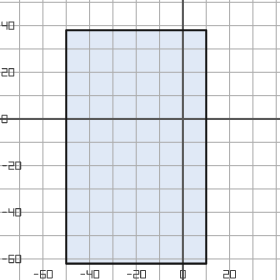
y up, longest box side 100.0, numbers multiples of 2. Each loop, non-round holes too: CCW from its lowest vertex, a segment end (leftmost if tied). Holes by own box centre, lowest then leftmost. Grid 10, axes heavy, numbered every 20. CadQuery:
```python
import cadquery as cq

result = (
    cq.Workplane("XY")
    .moveTo(-50.0, -62.0)
    .lineTo(10.0, -62.0)
    .lineTo(10.0, 38.0)
    .lineTo(-50.0, 38.0)
    .close()
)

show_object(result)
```